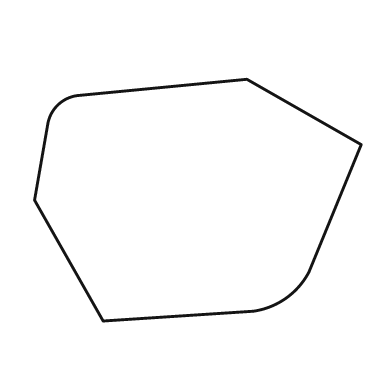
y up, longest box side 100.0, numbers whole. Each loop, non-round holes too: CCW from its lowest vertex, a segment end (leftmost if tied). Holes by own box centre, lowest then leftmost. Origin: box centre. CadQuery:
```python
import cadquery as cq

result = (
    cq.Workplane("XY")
    .moveTo(-29.0, -37.0)
    .lineTo(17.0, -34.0)
    .threePointArc((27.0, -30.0), (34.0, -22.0))
    .lineTo(50.0, 17.0)
    .lineTo(15.0, 37.0)
    .lineTo(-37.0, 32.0)
    .threePointArc((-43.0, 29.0), (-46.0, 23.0))
    .lineTo(-50.0, 0.0)
    .close()
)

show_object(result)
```